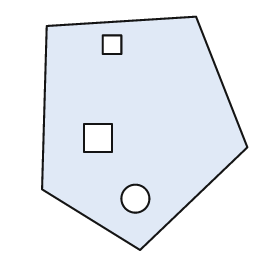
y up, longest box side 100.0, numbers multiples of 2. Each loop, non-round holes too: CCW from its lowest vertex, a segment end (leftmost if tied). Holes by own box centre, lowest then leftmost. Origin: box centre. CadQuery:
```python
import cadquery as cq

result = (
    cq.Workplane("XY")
    .moveTo(-2.0, -50.0)
    .lineTo(44.0, -6.0)
    .lineTo(22.0, 50.0)
    .lineTo(-42.0, 46.0)
    .lineTo(-44.0, -24.0)
    .close()
    .moveTo(-4.0, -28.0)
    .circle(6.0)
    .moveTo(-26.0, -8.0)
    .lineTo(-14.0, -8.0)
    .lineTo(-14.0, 4.0)
    .lineTo(-26.0, 4.0)
    .close()
    .moveTo(-18.0, 34.0)
    .lineTo(-10.0, 34.0)
    .lineTo(-10.0, 42.0)
    .lineTo(-18.0, 42.0)
    .close()
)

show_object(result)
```